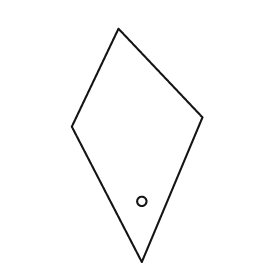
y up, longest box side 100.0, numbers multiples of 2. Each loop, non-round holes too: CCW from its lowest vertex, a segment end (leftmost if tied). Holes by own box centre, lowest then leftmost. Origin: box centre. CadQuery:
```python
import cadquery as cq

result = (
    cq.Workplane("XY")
    .moveTo(2.0, -50.0)
    .lineTo(28.0, 12.0)
    .lineTo(-8.0, 50.0)
    .lineTo(-28.0, 8.0)
    .close()
    .moveTo(2.0, -24.0)
    .circle(2.0)
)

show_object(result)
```